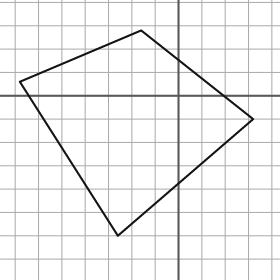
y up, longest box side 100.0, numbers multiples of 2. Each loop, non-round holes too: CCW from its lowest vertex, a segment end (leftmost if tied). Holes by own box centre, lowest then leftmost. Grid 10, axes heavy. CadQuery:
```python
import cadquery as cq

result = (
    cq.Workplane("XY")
    .moveTo(-26.0, -60.0)
    .lineTo(32.0, -10.0)
    .lineTo(-16.0, 28.0)
    .lineTo(-68.0, 6.0)
    .close()
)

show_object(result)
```